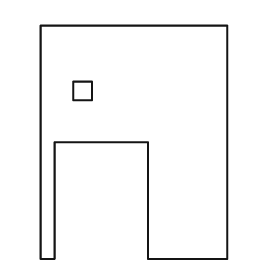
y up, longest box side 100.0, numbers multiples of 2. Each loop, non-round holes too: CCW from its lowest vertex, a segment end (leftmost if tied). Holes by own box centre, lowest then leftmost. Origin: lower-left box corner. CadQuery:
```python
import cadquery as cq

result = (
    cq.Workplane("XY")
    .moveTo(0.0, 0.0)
    .lineTo(6.0, 0.0)
    .lineTo(6.0, 50.0)
    .lineTo(46.0, 50.0)
    .lineTo(46.0, 0.0)
    .lineTo(80.0, 0.0)
    .lineTo(80.0, 100.0)
    .lineTo(0.0, 100.0)
    .close()
    .moveTo(14.0, 68.0)
    .lineTo(22.0, 68.0)
    .lineTo(22.0, 76.0)
    .lineTo(14.0, 76.0)
    .close()
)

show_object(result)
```